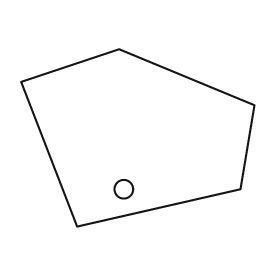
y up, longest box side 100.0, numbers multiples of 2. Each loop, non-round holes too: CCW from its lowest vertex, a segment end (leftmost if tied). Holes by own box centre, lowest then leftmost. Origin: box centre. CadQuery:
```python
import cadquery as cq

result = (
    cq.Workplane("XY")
    .moveTo(-26.0, -38.0)
    .lineTo(44.0, -22.0)
    .lineTo(50.0, 14.0)
    .lineTo(-8.0, 38.0)
    .lineTo(-50.0, 24.0)
    .close()
    .moveTo(-6.0, -22.0)
    .circle(4.0)
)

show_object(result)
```